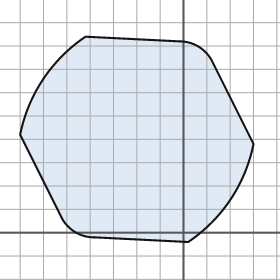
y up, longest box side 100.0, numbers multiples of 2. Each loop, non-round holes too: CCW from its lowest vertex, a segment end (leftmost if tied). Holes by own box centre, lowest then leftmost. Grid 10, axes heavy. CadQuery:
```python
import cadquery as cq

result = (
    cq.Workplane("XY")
    .moveTo(2.0, -4.0)
    .threePointArc((20.0, 14.0), (30.0, 38.0))
    .lineTo(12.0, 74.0)
    .threePointArc((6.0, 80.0), (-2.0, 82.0))
    .lineTo(-42.0, 84.0)
    .threePointArc((-60.0, 66.0), (-70.0, 42.0))
    .lineTo(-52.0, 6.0)
    .threePointArc((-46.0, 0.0), (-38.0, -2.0))
    .close()
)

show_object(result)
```